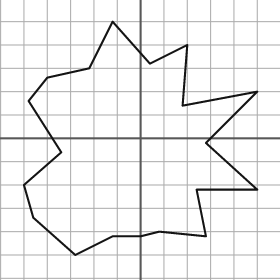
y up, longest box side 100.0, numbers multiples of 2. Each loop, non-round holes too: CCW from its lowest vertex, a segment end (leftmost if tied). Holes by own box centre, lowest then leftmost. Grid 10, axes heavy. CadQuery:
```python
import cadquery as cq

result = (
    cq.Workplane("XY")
    .moveTo(-28.0, -50.0)
    .lineTo(-12.0, -42.0)
    .lineTo(0.0, -42.0)
    .lineTo(8.0, -40.0)
    .lineTo(28.0, -42.0)
    .lineTo(24.0, -22.0)
    .lineTo(50.0, -22.0)
    .lineTo(28.0, -2.0)
    .lineTo(50.0, 20.0)
    .lineTo(18.0, 14.0)
    .lineTo(20.0, 40.0)
    .lineTo(4.0, 32.0)
    .lineTo(-12.0, 50.0)
    .lineTo(-22.0, 30.0)
    .lineTo(-40.0, 26.0)
    .lineTo(-48.0, 16.0)
    .lineTo(-34.0, -6.0)
    .lineTo(-50.0, -20.0)
    .lineTo(-46.0, -34.0)
    .close()
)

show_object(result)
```